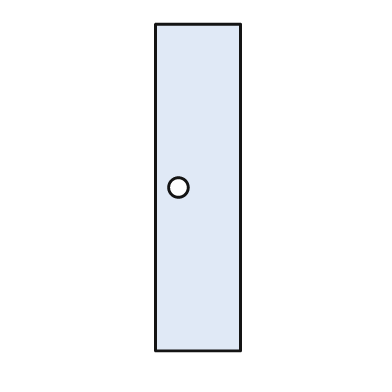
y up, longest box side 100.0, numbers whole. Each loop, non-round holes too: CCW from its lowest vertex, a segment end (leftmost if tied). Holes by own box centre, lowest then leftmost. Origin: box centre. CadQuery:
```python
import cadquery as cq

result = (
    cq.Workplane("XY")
    .moveTo(-13.0, -50.0)
    .lineTo(13.0, -50.0)
    .lineTo(13.0, 50.0)
    .lineTo(-13.0, 50.0)
    .close()
    .moveTo(-6.0, 0.0)
    .circle(3.0)
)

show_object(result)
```